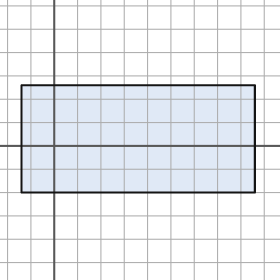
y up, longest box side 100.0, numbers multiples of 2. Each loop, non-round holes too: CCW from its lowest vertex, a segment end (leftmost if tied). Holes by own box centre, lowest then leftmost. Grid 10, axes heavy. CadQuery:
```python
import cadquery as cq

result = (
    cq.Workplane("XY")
    .moveTo(-14.0, -20.0)
    .lineTo(86.0, -20.0)
    .lineTo(86.0, 26.0)
    .lineTo(-14.0, 26.0)
    .close()
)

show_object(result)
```